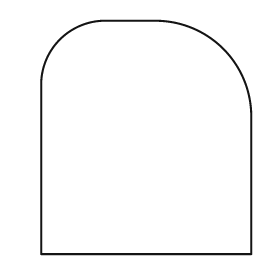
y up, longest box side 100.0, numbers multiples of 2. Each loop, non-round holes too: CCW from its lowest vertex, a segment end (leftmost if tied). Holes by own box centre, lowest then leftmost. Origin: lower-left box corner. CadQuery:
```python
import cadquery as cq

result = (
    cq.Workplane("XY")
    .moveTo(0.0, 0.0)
    .lineTo(90.0, 0.0)
    .lineTo(90.0, 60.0)
    .threePointArc((78.0, 88.0), (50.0, 100.0))
    .lineTo(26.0, 100.0)
    .threePointArc((8.0, 92.0), (0.0, 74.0))
    .close()
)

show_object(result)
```